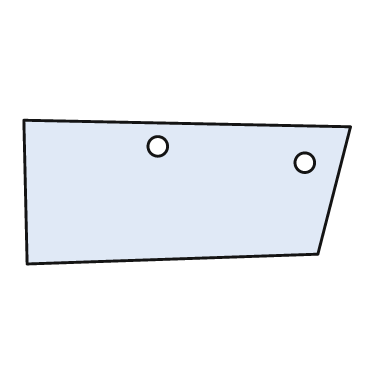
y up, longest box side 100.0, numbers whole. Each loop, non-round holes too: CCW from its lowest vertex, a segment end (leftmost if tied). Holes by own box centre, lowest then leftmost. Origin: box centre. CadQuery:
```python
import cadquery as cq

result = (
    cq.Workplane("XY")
    .moveTo(-49.0, -22.0)
    .lineTo(40.0, -19.0)
    .lineTo(50.0, 20.0)
    .lineTo(-50.0, 22.0)
    .close()
    .moveTo(36.0, 9.0)
    .circle(3.0)
    .moveTo(-9.0, 14.0)
    .circle(3.0)
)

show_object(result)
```